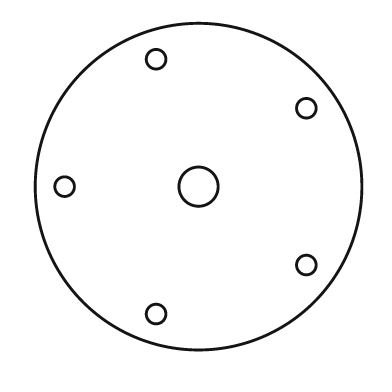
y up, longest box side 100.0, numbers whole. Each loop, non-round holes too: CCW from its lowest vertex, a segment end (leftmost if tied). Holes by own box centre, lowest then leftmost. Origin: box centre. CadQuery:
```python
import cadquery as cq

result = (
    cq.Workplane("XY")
    .moveTo(0.0, 0.0)
    .circle(50.0)
    .moveTo(-13.0, -39.0)
    .circle(3.0)
    .moveTo(33.0, -24.0)
    .circle(3.0)
    .moveTo(-41.0, 0.0)
    .circle(3.0)
    .moveTo(0.0, 0.0)
    .circle(6.0)
    .moveTo(33.0, 24.0)
    .circle(3.0)
    .moveTo(-13.0, 39.0)
    .circle(3.0)
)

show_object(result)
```